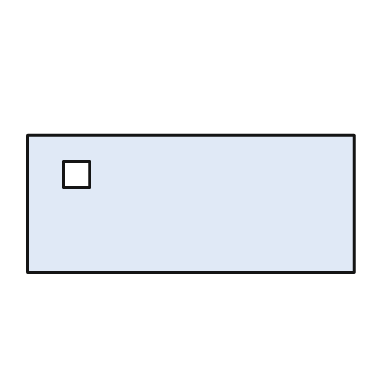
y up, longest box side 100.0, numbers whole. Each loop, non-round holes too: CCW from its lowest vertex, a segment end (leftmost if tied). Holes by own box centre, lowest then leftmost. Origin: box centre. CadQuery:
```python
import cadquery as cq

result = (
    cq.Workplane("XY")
    .moveTo(-50.0, -21.0)
    .lineTo(50.0, -21.0)
    .lineTo(50.0, 21.0)
    .lineTo(-50.0, 21.0)
    .close()
    .moveTo(-39.0, 5.0)
    .lineTo(-31.0, 5.0)
    .lineTo(-31.0, 13.0)
    .lineTo(-39.0, 13.0)
    .close()
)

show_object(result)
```